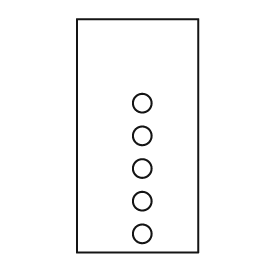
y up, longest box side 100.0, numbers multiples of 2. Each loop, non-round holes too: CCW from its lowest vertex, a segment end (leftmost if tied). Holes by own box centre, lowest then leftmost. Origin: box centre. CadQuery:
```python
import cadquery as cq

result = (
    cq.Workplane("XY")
    .moveTo(-26.0, -50.0)
    .lineTo(26.0, -50.0)
    .lineTo(26.0, 50.0)
    .lineTo(-26.0, 50.0)
    .close()
    .moveTo(2.0, -42.0)
    .circle(4.0)
    .moveTo(2.0, -28.0)
    .circle(4.0)
    .moveTo(2.0, -14.0)
    .circle(4.0)
    .moveTo(2.0, 0.0)
    .circle(4.0)
    .moveTo(2.0, 14.0)
    .circle(4.0)
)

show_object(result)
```